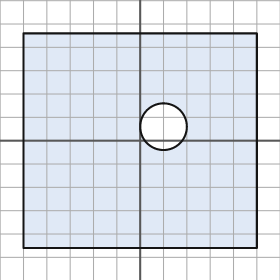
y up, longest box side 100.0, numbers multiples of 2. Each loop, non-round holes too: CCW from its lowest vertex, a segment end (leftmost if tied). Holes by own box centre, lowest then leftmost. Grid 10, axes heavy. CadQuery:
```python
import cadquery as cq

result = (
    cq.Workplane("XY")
    .moveTo(-50.0, -46.0)
    .lineTo(50.0, -46.0)
    .lineTo(50.0, 46.0)
    .lineTo(-50.0, 46.0)
    .close()
    .moveTo(10.0, 6.0)
    .circle(10.0)
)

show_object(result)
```